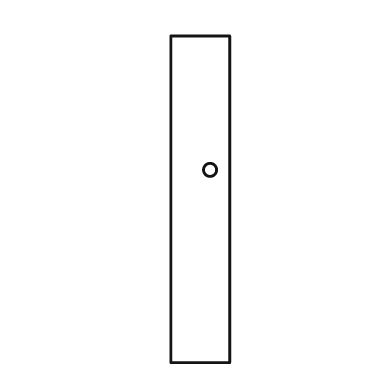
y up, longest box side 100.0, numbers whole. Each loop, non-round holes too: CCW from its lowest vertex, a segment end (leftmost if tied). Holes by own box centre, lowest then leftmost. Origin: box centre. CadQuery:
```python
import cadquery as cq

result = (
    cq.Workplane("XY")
    .moveTo(-9.0, -50.0)
    .lineTo(9.0, -50.0)
    .lineTo(9.0, 50.0)
    .lineTo(-9.0, 50.0)
    .close()
    .moveTo(3.0, 9.0)
    .circle(2.0)
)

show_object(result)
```